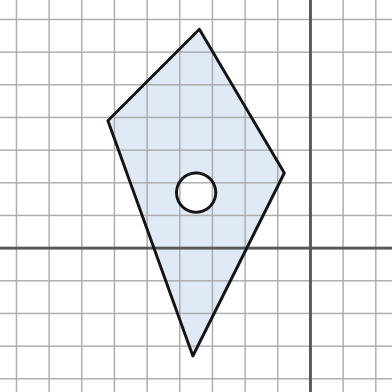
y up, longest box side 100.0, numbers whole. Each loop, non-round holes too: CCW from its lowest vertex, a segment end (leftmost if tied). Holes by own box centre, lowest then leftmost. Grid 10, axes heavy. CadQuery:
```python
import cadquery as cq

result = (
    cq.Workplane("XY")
    .moveTo(-36.0, -33.0)
    .lineTo(-8.0, 23.0)
    .lineTo(-34.0, 67.0)
    .lineTo(-62.0, 39.0)
    .close()
    .moveTo(-35.0, 17.0)
    .circle(6.0)
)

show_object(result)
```